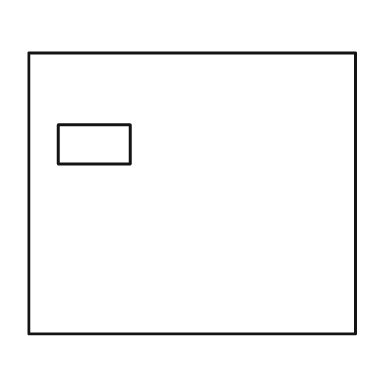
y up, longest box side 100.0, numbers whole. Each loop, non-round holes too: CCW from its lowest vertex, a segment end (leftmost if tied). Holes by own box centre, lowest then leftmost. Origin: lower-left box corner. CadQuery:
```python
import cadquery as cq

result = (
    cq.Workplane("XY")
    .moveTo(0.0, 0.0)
    .lineTo(100.0, 0.0)
    .lineTo(100.0, 86.0)
    .lineTo(0.0, 86.0)
    .close()
    .moveTo(9.0, 52.0)
    .lineTo(31.0, 52.0)
    .lineTo(31.0, 64.0)
    .lineTo(9.0, 64.0)
    .close()
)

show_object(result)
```